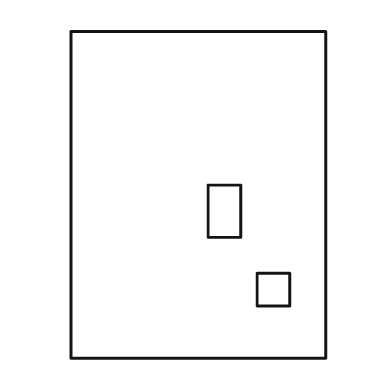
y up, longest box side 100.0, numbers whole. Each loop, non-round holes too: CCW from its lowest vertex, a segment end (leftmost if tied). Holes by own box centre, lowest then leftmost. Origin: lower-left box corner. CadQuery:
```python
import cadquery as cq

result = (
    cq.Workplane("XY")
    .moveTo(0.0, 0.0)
    .lineTo(78.0, 0.0)
    .lineTo(78.0, 100.0)
    .lineTo(0.0, 100.0)
    .close()
    .moveTo(57.0, 16.0)
    .lineTo(67.0, 16.0)
    .lineTo(67.0, 26.0)
    .lineTo(57.0, 26.0)
    .close()
    .moveTo(42.0, 37.0)
    .lineTo(52.0, 37.0)
    .lineTo(52.0, 53.0)
    .lineTo(42.0, 53.0)
    .close()
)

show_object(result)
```